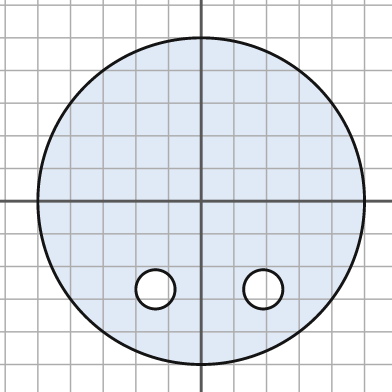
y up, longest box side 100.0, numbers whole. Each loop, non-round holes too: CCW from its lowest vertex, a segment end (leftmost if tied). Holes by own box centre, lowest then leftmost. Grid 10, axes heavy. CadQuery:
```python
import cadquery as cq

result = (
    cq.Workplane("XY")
    .moveTo(0.0, 0.0)
    .circle(50.0)
    .moveTo(-14.0, -27.0)
    .circle(6.0)
    .moveTo(19.0, -27.0)
    .circle(6.0)
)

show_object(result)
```